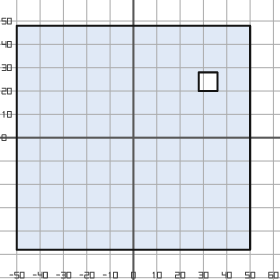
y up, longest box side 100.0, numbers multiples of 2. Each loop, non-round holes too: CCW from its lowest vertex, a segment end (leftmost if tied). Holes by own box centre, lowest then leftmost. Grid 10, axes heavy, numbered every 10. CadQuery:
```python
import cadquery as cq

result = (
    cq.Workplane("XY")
    .moveTo(-50.0, -48.0)
    .lineTo(50.0, -48.0)
    .lineTo(50.0, 48.0)
    .lineTo(-50.0, 48.0)
    .close()
    .moveTo(28.0, 20.0)
    .lineTo(36.0, 20.0)
    .lineTo(36.0, 28.0)
    .lineTo(28.0, 28.0)
    .close()
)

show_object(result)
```